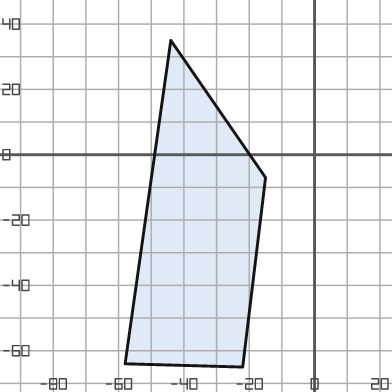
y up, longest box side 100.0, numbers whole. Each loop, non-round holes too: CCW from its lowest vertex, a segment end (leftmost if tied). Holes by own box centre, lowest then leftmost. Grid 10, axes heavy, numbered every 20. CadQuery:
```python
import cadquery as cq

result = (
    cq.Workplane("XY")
    .moveTo(-22.0, -65.0)
    .lineTo(-15.0, -7.0)
    .lineTo(-44.0, 35.0)
    .lineTo(-58.0, -64.0)
    .close()
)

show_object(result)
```